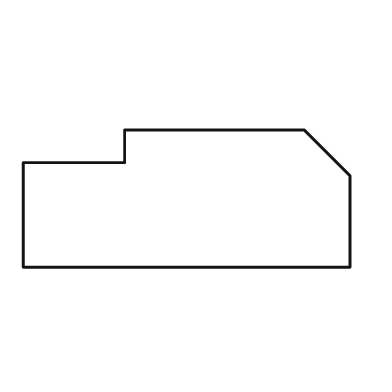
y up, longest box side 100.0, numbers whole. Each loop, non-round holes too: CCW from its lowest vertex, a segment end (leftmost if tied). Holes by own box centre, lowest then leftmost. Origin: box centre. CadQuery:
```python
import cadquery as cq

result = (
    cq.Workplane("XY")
    .moveTo(-50.0, -21.0)
    .lineTo(50.0, -21.0)
    .lineTo(50.0, 7.0)
    .lineTo(36.0, 21.0)
    .lineTo(-19.0, 21.0)
    .lineTo(-19.0, 11.0)
    .lineTo(-50.0, 11.0)
    .close()
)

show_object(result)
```